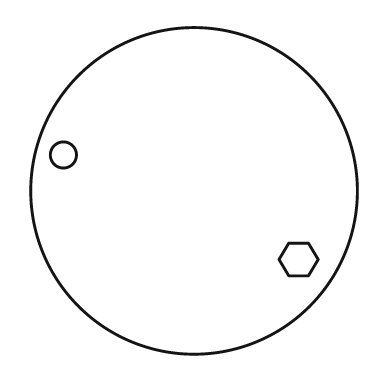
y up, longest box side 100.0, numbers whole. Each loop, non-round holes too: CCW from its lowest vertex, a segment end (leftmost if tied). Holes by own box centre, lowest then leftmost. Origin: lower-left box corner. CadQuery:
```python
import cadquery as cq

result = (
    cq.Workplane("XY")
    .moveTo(50.0, 50.0)
    .circle(50.0)
    .moveTo(79.0, 24.0)
    .lineTo(85.0, 24.0)
    .lineTo(88.0, 29.0)
    .lineTo(85.0, 34.0)
    .lineTo(79.0, 34.0)
    .lineTo(76.0, 29.0)
    .close()
    .moveTo(10.0, 61.0)
    .circle(4.0)
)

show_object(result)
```